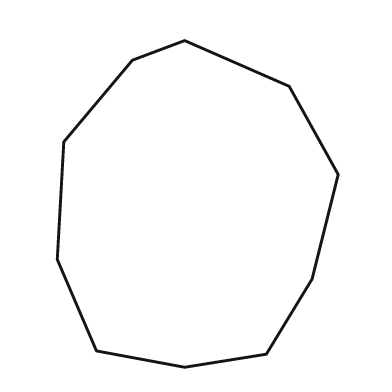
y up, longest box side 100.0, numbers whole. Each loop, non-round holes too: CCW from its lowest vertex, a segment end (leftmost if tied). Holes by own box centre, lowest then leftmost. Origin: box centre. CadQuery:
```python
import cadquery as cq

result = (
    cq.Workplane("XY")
    .moveTo(-4.0, -50.0)
    .lineTo(21.0, -46.0)
    .lineTo(35.0, -23.0)
    .lineTo(43.0, 9.0)
    .lineTo(28.0, 36.0)
    .lineTo(-4.0, 50.0)
    .lineTo(-20.0, 44.0)
    .lineTo(-41.0, 19.0)
    .lineTo(-43.0, -17.0)
    .lineTo(-31.0, -45.0)
    .close()
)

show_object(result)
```